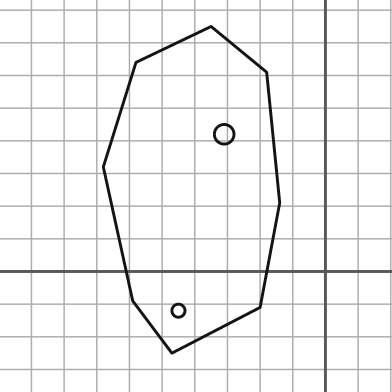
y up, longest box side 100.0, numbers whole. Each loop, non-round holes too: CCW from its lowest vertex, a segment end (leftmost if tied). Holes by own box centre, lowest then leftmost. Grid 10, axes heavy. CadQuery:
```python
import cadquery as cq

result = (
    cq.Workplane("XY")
    .moveTo(-47.0, -25.0)
    .lineTo(-20.0, -11.0)
    .lineTo(-14.0, 21.0)
    .lineTo(-18.0, 61.0)
    .lineTo(-35.0, 75.0)
    .lineTo(-58.0, 64.0)
    .lineTo(-68.0, 32.0)
    .lineTo(-59.0, -9.0)
    .close()
    .moveTo(-45.0, -12.0)
    .circle(2.0)
    .moveTo(-31.0, 42.0)
    .circle(3.0)
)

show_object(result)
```